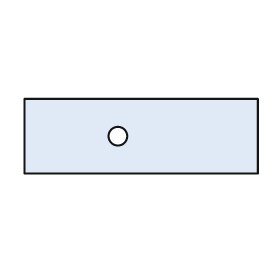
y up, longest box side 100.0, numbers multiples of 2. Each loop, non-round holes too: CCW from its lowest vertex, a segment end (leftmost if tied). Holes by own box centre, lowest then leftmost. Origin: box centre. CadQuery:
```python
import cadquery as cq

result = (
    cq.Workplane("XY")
    .moveTo(-50.0, -16.0)
    .lineTo(50.0, -16.0)
    .lineTo(50.0, 16.0)
    .lineTo(-50.0, 16.0)
    .close()
    .moveTo(-10.0, 0.0)
    .circle(4.0)
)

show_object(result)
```